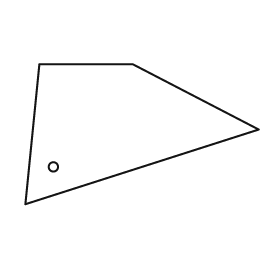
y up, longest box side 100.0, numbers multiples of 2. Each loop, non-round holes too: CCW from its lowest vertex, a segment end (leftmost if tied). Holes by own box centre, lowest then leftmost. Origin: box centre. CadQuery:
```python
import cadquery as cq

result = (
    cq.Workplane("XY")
    .moveTo(-50.0, -30.0)
    .lineTo(50.0, 2.0)
    .lineTo(-4.0, 30.0)
    .lineTo(-44.0, 30.0)
    .close()
    .moveTo(-38.0, -14.0)
    .circle(2.0)
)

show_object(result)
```